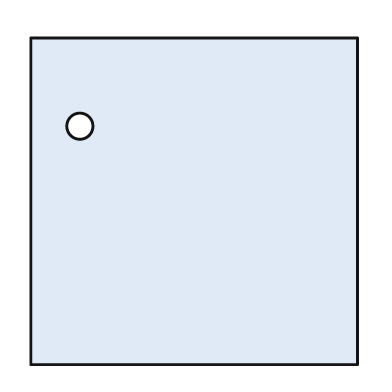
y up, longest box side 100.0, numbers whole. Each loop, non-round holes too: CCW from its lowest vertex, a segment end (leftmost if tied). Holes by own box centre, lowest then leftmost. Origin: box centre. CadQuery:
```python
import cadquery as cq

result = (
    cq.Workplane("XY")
    .moveTo(-50.0, -50.0)
    .lineTo(50.0, -50.0)
    .lineTo(50.0, 50.0)
    .lineTo(-50.0, 50.0)
    .close()
    .moveTo(-35.0, 23.0)
    .circle(4.0)
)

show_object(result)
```